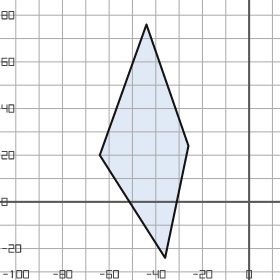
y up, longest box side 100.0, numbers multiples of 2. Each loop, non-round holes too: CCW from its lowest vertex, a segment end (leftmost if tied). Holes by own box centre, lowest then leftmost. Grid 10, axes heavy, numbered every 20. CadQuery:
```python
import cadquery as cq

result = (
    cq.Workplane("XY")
    .moveTo(-36.0, -24.0)
    .lineTo(-26.0, 24.0)
    .lineTo(-44.0, 76.0)
    .lineTo(-64.0, 20.0)
    .close()
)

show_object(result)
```